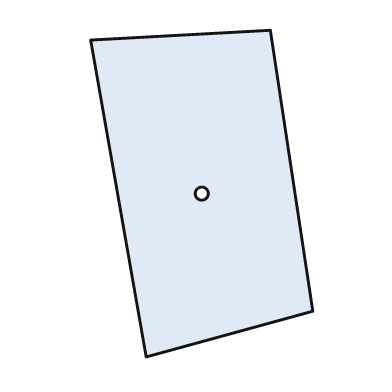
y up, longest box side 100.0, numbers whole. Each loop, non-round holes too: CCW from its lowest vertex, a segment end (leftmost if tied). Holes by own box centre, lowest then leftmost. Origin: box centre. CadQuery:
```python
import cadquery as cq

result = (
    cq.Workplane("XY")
    .moveTo(-17.0, -50.0)
    .lineTo(34.0, -36.0)
    .lineTo(21.0, 50.0)
    .lineTo(-34.0, 47.0)
    .close()
    .moveTo(0.0, 0.0)
    .circle(2.0)
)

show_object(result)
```